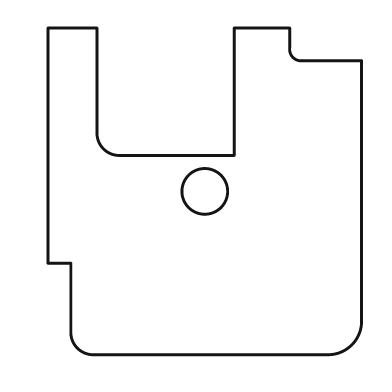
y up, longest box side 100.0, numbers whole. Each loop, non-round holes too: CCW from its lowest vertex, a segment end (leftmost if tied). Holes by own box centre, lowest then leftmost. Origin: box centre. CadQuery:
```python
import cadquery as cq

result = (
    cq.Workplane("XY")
    .moveTo(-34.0, -50.0)
    .lineTo(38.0, -50.0)
    .threePointArc((45.0, -47.0), (48.0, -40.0))
    .lineTo(48.0, 40.0)
    .lineTo(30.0, 40.0)
    .threePointArc((27.0, 41.0), (26.0, 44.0))
    .lineTo(26.0, 50.0)
    .lineTo(9.0, 50.0)
    .lineTo(9.0, 11.0)
    .lineTo(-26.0, 11.0)
    .threePointArc((-31.0, 13.0), (-33.0, 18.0))
    .lineTo(-33.0, 50.0)
    .lineTo(-48.0, 50.0)
    .lineTo(-48.0, -22.0)
    .lineTo(-41.0, -22.0)
    .lineTo(-41.0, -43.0)
    .threePointArc((-39.0, -48.0), (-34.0, -50.0))
    .close()
    .moveTo(0.0, 0.0)
    .circle(7.0)
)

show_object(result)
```